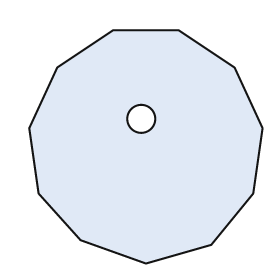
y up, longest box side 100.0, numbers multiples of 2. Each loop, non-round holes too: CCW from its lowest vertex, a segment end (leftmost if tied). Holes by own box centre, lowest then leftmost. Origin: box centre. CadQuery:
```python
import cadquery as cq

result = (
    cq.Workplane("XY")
    .moveTo(0.0, -50.0)
    .lineTo(28.0, -42.0)
    .lineTo(46.0, -20.0)
    .lineTo(50.0, 8.0)
    .lineTo(38.0, 34.0)
    .lineTo(14.0, 50.0)
    .lineTo(-14.0, 50.0)
    .lineTo(-38.0, 34.0)
    .lineTo(-50.0, 8.0)
    .lineTo(-46.0, -20.0)
    .lineTo(-28.0, -40.0)
    .close()
    .moveTo(-2.0, 12.0)
    .circle(6.0)
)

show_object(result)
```